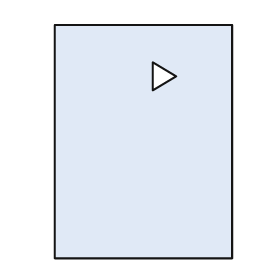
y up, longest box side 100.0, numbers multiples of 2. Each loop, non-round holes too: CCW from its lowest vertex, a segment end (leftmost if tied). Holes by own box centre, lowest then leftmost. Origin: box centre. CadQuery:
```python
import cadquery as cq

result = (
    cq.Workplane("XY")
    .moveTo(-38.0, -50.0)
    .lineTo(38.0, -50.0)
    .lineTo(38.0, 50.0)
    .lineTo(-38.0, 50.0)
    .close()
    .moveTo(4.0, 22.0)
    .lineTo(14.0, 28.0)
    .lineTo(4.0, 34.0)
    .close()
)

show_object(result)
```